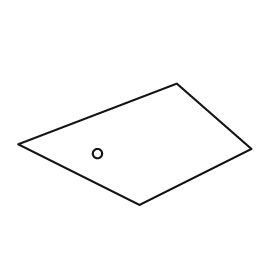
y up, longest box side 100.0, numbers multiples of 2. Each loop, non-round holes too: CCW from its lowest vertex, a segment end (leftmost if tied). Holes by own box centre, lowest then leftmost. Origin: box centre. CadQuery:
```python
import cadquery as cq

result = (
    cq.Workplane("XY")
    .moveTo(2.0, -26.0)
    .lineTo(50.0, -2.0)
    .lineTo(18.0, 26.0)
    .lineTo(-50.0, 0.0)
    .close()
    .moveTo(-16.0, -4.0)
    .circle(2.0)
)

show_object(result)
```